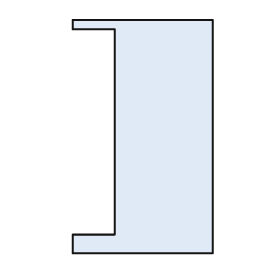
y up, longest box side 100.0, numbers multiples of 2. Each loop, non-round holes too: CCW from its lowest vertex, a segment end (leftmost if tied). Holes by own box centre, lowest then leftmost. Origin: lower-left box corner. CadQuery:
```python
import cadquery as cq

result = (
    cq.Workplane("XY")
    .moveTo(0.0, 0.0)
    .lineTo(60.0, 0.0)
    .lineTo(60.0, 100.0)
    .lineTo(0.0, 100.0)
    .lineTo(0.0, 96.0)
    .lineTo(18.0, 96.0)
    .lineTo(18.0, 8.0)
    .lineTo(0.0, 8.0)
    .close()
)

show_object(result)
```